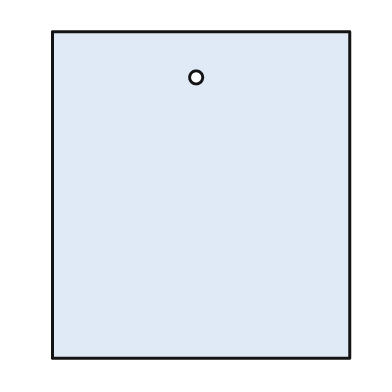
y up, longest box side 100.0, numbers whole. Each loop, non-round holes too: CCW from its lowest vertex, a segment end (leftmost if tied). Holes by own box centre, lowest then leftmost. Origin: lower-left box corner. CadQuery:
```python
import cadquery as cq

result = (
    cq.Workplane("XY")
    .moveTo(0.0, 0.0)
    .lineTo(91.0, 0.0)
    .lineTo(91.0, 100.0)
    .lineTo(0.0, 100.0)
    .close()
    .moveTo(44.0, 86.0)
    .circle(2.0)
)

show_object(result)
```